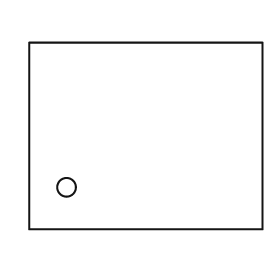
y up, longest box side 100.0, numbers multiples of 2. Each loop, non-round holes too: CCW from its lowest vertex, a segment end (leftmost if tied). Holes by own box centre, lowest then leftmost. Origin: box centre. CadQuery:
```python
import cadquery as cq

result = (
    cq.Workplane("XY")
    .moveTo(-50.0, -40.0)
    .lineTo(50.0, -40.0)
    .lineTo(50.0, 40.0)
    .lineTo(-50.0, 40.0)
    .close()
    .moveTo(-34.0, -22.0)
    .circle(4.0)
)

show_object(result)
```